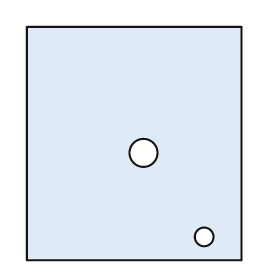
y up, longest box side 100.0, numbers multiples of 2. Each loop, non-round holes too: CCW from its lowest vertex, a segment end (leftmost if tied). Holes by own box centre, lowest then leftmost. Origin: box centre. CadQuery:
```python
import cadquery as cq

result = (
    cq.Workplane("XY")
    .moveTo(-46.0, -50.0)
    .lineTo(46.0, -50.0)
    .lineTo(46.0, 50.0)
    .lineTo(-46.0, 50.0)
    .close()
    .moveTo(30.0, -40.0)
    .circle(4.0)
    .moveTo(4.0, -4.0)
    .circle(6.0)
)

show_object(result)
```